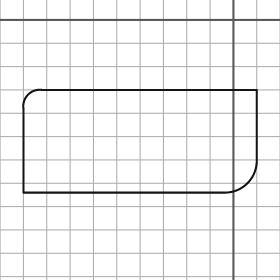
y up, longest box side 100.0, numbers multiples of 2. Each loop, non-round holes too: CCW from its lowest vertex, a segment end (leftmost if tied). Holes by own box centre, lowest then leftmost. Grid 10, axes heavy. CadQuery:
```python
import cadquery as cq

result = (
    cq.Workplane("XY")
    .moveTo(-90.0, -74.0)
    .lineTo(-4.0, -74.0)
    .threePointArc((6.0, -70.0), (10.0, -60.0))
    .lineTo(10.0, -30.0)
    .lineTo(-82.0, -30.0)
    .threePointArc((-88.0, -32.0), (-90.0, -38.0))
    .close()
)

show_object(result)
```